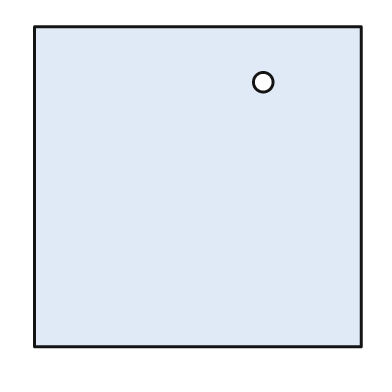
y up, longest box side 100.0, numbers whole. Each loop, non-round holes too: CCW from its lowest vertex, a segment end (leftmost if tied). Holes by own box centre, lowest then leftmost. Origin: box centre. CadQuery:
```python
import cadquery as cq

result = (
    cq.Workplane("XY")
    .moveTo(-50.0, -49.0)
    .lineTo(50.0, -49.0)
    .lineTo(50.0, 49.0)
    .lineTo(-50.0, 49.0)
    .close()
    .moveTo(20.0, 32.0)
    .circle(3.0)
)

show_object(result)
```